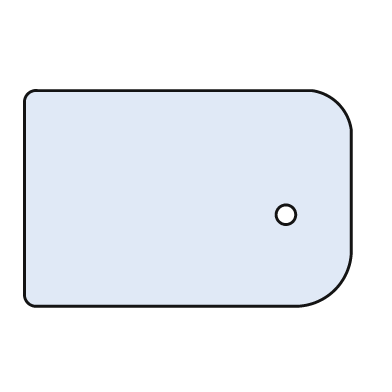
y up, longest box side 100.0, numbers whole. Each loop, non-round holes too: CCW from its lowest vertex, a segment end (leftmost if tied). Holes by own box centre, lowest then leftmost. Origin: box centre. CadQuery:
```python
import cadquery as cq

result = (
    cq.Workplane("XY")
    .moveTo(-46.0, -33.0)
    .lineTo(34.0, -33.0)
    .threePointArc((45.0, -28.0), (50.0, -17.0))
    .lineTo(50.0, 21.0)
    .threePointArc((46.0, 29.0), (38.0, 33.0))
    .lineTo(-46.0, 33.0)
    .threePointArc((-49.0, 32.0), (-50.0, 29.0))
    .lineTo(-50.0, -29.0)
    .threePointArc((-49.0, -32.0), (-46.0, -33.0))
    .close()
    .moveTo(30.0, -5.0)
    .circle(3.0)
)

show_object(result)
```